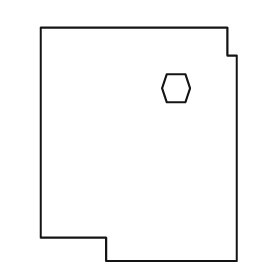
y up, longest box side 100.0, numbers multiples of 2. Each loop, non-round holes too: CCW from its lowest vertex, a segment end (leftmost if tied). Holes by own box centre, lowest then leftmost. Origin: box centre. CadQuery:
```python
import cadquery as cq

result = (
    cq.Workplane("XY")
    .moveTo(-14.0, -50.0)
    .lineTo(42.0, -50.0)
    .lineTo(42.0, 38.0)
    .lineTo(38.0, 38.0)
    .lineTo(38.0, 50.0)
    .lineTo(-42.0, 50.0)
    .lineTo(-42.0, -40.0)
    .lineTo(-14.0, -40.0)
    .close()
    .moveTo(12.0, 18.0)
    .lineTo(20.0, 18.0)
    .lineTo(22.0, 24.0)
    .lineTo(20.0, 30.0)
    .lineTo(12.0, 30.0)
    .lineTo(10.0, 24.0)
    .close()
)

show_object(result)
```